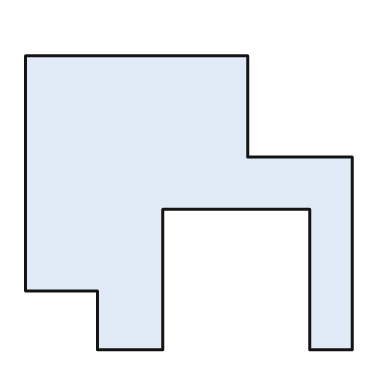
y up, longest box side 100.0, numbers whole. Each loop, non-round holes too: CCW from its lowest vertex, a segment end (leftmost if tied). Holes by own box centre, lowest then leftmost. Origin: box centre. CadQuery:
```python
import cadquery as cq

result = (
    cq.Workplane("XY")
    .moveTo(-28.0, -45.0)
    .lineTo(-8.0, -45.0)
    .lineTo(-8.0, -2.0)
    .lineTo(37.0, -2.0)
    .lineTo(37.0, -45.0)
    .lineTo(50.0, -45.0)
    .lineTo(50.0, 14.0)
    .lineTo(18.0, 14.0)
    .lineTo(18.0, 45.0)
    .lineTo(-50.0, 45.0)
    .lineTo(-50.0, -27.0)
    .lineTo(-28.0, -27.0)
    .close()
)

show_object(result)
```